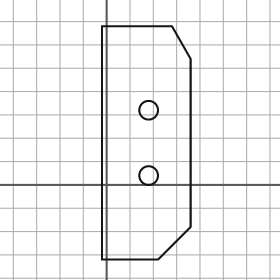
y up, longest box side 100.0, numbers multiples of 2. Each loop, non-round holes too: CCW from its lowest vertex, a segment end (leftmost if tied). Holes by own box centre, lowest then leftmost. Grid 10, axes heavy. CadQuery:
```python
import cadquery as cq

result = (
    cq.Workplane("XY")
    .moveTo(-2.0, -32.0)
    .lineTo(22.0, -32.0)
    .lineTo(36.0, -18.0)
    .lineTo(36.0, 54.0)
    .lineTo(28.0, 68.0)
    .lineTo(-2.0, 68.0)
    .close()
    .moveTo(18.0, 4.0)
    .circle(4.0)
    .moveTo(18.0, 32.0)
    .circle(4.0)
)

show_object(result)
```